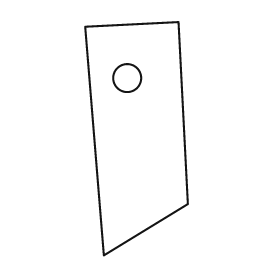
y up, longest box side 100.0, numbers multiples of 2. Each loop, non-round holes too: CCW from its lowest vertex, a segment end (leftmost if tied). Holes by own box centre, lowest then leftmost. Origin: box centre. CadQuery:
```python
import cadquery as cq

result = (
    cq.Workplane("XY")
    .moveTo(-14.0, -50.0)
    .lineTo(22.0, -28.0)
    .lineTo(18.0, 50.0)
    .lineTo(-22.0, 48.0)
    .close()
    .moveTo(-4.0, 26.0)
    .circle(6.0)
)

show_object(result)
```